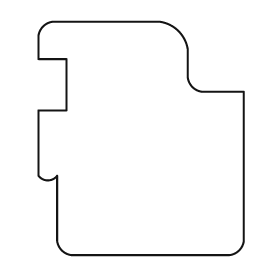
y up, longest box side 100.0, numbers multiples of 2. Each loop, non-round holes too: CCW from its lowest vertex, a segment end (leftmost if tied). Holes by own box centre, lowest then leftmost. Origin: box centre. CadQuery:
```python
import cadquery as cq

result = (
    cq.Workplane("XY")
    .moveTo(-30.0, -50.0)
    .lineTo(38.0, -50.0)
    .threePointArc((42.0, -48.0), (44.0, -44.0))
    .lineTo(44.0, 20.0)
    .lineTo(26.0, 20.0)
    .threePointArc((22.0, 22.0), (20.0, 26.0))
    .lineTo(20.0, 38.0)
    .threePointArc((16.0, 46.0), (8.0, 50.0))
    .lineTo(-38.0, 50.0)
    .threePointArc((-42.0, 48.0), (-44.0, 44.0))
    .lineTo(-44.0, 34.0)
    .lineTo(-32.0, 34.0)
    .lineTo(-32.0, 12.0)
    .lineTo(-44.0, 12.0)
    .lineTo(-44.0, -16.0)
    .threePointArc((-40.0, -18.0), (-36.0, -16.0))
    .lineTo(-36.0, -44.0)
    .threePointArc((-34.0, -48.0), (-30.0, -50.0))
    .close()
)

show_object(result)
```